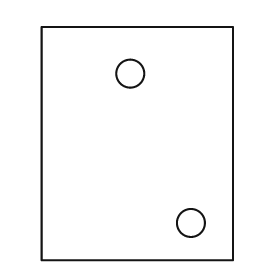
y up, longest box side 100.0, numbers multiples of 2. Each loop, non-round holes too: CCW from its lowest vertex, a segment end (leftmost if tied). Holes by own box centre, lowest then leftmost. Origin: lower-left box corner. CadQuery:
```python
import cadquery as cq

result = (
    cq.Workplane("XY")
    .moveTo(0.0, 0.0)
    .lineTo(82.0, 0.0)
    .lineTo(82.0, 100.0)
    .lineTo(0.0, 100.0)
    .close()
    .moveTo(64.0, 16.0)
    .circle(6.0)
    .moveTo(38.0, 80.0)
    .circle(6.0)
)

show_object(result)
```